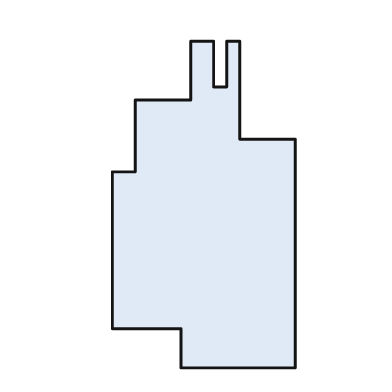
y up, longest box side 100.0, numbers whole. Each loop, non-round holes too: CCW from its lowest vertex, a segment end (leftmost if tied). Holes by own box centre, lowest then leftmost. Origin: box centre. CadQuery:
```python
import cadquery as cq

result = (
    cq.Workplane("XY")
    .moveTo(-7.0, -50.0)
    .lineTo(28.0, -50.0)
    .lineTo(28.0, 20.0)
    .lineTo(11.0, 20.0)
    .lineTo(11.0, 50.0)
    .lineTo(7.0, 50.0)
    .lineTo(7.0, 36.0)
    .lineTo(3.0, 36.0)
    .lineTo(3.0, 50.0)
    .lineTo(-4.0, 50.0)
    .lineTo(-4.0, 32.0)
    .lineTo(-21.0, 32.0)
    .lineTo(-21.0, 10.0)
    .lineTo(-28.0, 10.0)
    .lineTo(-28.0, -38.0)
    .lineTo(-7.0, -38.0)
    .close()
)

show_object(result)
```